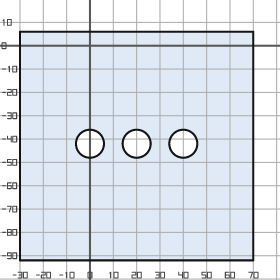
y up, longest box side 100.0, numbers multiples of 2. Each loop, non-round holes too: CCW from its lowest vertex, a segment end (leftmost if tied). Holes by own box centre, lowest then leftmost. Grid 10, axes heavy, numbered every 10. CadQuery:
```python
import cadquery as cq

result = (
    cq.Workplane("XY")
    .moveTo(-30.0, -92.0)
    .lineTo(70.0, -92.0)
    .lineTo(70.0, 6.0)
    .lineTo(-30.0, 6.0)
    .close()
    .moveTo(0.0, -42.0)
    .circle(6.0)
    .moveTo(20.0, -42.0)
    .circle(6.0)
    .moveTo(40.0, -42.0)
    .circle(6.0)
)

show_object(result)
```